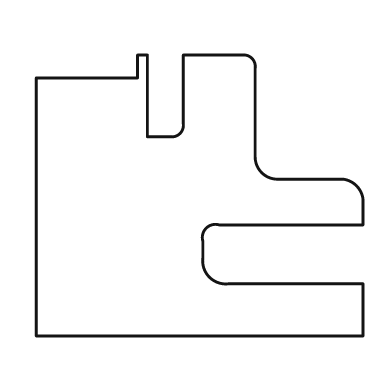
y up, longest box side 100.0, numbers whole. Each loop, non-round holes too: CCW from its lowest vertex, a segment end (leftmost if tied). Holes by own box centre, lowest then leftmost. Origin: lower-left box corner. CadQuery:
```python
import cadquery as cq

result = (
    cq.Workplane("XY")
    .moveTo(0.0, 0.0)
    .lineTo(100.0, 0.0)
    .lineTo(100.0, 16.0)
    .lineTo(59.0, 16.0)
    .threePointArc((53.0, 18.0), (51.0, 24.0))
    .lineTo(51.0, 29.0)
    .threePointArc((52.0, 33.0), (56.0, 34.0))
    .lineTo(100.0, 34.0)
    .lineTo(100.0, 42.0)
    .threePointArc((98.0, 46.0), (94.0, 48.0))
    .lineTo(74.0, 48.0)
    .threePointArc((69.0, 50.0), (67.0, 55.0))
    .lineTo(67.0, 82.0)
    .threePointArc((66.0, 85.0), (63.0, 86.0))
    .lineTo(45.0, 86.0)
    .lineTo(45.0, 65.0)
    .threePointArc((44.0, 62.0), (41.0, 61.0))
    .lineTo(34.0, 61.0)
    .lineTo(34.0, 86.0)
    .lineTo(31.0, 86.0)
    .lineTo(31.0, 79.0)
    .lineTo(0.0, 79.0)
    .close()
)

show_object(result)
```